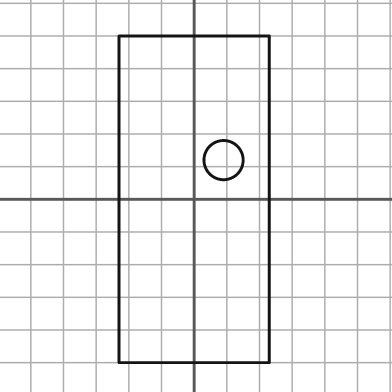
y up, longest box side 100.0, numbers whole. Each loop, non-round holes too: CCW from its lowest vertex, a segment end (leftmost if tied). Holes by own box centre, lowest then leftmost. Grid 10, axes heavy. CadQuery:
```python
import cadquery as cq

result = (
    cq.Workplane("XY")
    .moveTo(-23.0, -50.0)
    .lineTo(23.0, -50.0)
    .lineTo(23.0, 50.0)
    .lineTo(-23.0, 50.0)
    .close()
    .moveTo(9.0, 12.0)
    .circle(6.0)
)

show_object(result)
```